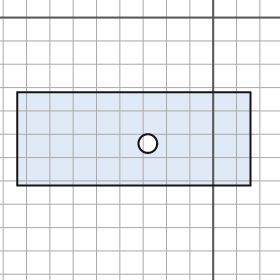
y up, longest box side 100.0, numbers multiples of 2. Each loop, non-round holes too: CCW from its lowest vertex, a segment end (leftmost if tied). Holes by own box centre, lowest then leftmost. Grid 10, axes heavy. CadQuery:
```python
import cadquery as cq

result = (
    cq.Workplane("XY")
    .moveTo(-84.0, -72.0)
    .lineTo(16.0, -72.0)
    .lineTo(16.0, -32.0)
    .lineTo(-84.0, -32.0)
    .close()
    .moveTo(-28.0, -54.0)
    .circle(4.0)
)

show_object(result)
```